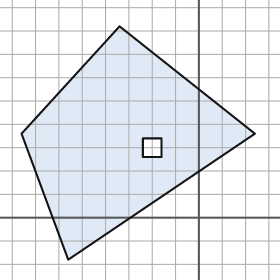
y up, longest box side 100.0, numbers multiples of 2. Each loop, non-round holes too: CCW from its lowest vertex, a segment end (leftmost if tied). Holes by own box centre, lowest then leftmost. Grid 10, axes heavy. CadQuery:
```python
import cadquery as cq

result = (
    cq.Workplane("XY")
    .moveTo(-56.0, -18.0)
    .lineTo(24.0, 36.0)
    .lineTo(-34.0, 82.0)
    .lineTo(-76.0, 36.0)
    .close()
    .moveTo(-24.0, 26.0)
    .lineTo(-16.0, 26.0)
    .lineTo(-16.0, 34.0)
    .lineTo(-24.0, 34.0)
    .close()
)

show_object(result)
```